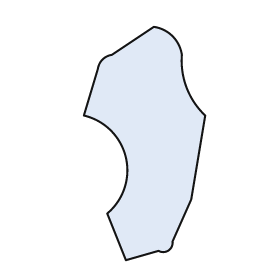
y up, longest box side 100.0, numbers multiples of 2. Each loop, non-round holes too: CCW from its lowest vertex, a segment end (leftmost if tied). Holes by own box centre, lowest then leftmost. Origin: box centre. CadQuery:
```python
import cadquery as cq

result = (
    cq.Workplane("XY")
    .moveTo(-8.0, -50.0)
    .lineTo(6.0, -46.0)
    .threePointArc((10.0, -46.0), (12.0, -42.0))
    .lineTo(20.0, -24.0)
    .lineTo(26.0, 12.0)
    .threePointArc((18.0, 24.0), (16.0, 38.0))
    .threePointArc((12.0, 46.0), (4.0, 50.0))
    .lineTo(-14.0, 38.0)
    .threePointArc((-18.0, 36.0), (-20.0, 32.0))
    .lineTo(-26.0, 12.0)
    .threePointArc((-8.0, -6.0), (-16.0, -30.0))
    .close()
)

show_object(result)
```